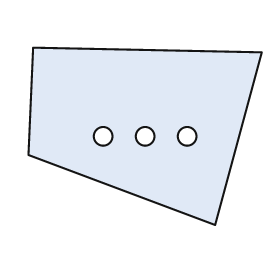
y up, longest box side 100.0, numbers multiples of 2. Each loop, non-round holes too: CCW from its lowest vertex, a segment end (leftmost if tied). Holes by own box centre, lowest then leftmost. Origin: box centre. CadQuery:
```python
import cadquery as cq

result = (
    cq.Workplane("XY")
    .moveTo(30.0, -38.0)
    .lineTo(50.0, 36.0)
    .lineTo(-48.0, 38.0)
    .lineTo(-50.0, -8.0)
    .close()
    .moveTo(-18.0, 0.0)
    .circle(4.0)
    .moveTo(0.0, 0.0)
    .circle(4.0)
    .moveTo(18.0, 0.0)
    .circle(4.0)
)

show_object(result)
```